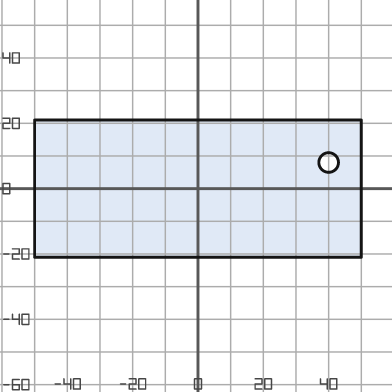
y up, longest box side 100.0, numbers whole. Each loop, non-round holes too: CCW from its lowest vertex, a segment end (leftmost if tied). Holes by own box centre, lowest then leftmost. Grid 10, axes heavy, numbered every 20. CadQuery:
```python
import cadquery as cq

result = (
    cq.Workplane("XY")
    .moveTo(-50.0, -21.0)
    .lineTo(50.0, -21.0)
    .lineTo(50.0, 21.0)
    .lineTo(-50.0, 21.0)
    .close()
    .moveTo(40.0, 8.0)
    .circle(3.0)
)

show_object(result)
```